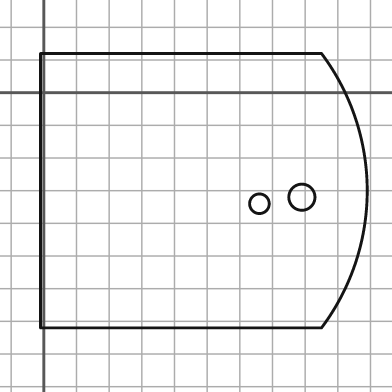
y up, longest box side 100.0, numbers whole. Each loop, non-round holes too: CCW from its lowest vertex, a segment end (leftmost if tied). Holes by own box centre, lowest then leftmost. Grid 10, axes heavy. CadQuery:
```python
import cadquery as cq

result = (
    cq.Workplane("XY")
    .moveTo(-1.0, -72.0)
    .lineTo(85.0, -72.0)
    .threePointArc((99.0, -30.0), (85.0, 12.0))
    .lineTo(-1.0, 12.0)
    .close()
    .moveTo(66.0, -34.0)
    .circle(3.0)
    .moveTo(79.0, -32.0)
    .circle(4.0)
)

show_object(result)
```